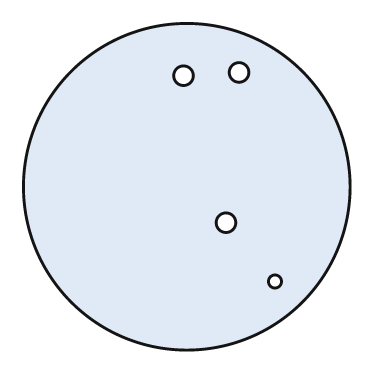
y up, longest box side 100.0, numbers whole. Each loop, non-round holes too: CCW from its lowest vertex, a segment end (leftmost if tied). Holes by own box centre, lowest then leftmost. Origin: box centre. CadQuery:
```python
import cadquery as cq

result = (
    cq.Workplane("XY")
    .moveTo(0.0, 0.0)
    .circle(50.0)
    .moveTo(27.0, -29.0)
    .circle(2.0)
    .moveTo(12.0, -11.0)
    .circle(3.0)
    .moveTo(-1.0, 34.0)
    .circle(3.0)
    .moveTo(16.0, 35.0)
    .circle(3.0)
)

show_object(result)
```